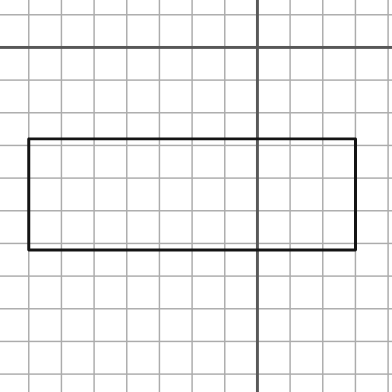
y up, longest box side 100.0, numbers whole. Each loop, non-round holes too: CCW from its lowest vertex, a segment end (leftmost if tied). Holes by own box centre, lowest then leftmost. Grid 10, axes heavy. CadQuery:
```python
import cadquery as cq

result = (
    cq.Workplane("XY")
    .moveTo(-70.0, -62.0)
    .lineTo(30.0, -62.0)
    .lineTo(30.0, -28.0)
    .lineTo(-70.0, -28.0)
    .close()
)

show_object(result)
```